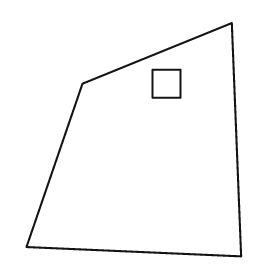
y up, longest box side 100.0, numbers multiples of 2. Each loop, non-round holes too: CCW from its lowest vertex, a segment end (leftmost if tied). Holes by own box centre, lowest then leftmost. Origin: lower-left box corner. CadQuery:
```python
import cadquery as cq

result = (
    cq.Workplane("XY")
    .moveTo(92.0, 0.0)
    .lineTo(88.0, 100.0)
    .lineTo(24.0, 74.0)
    .lineTo(0.0, 4.0)
    .close()
    .moveTo(54.0, 68.0)
    .lineTo(66.0, 68.0)
    .lineTo(66.0, 80.0)
    .lineTo(54.0, 80.0)
    .close()
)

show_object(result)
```